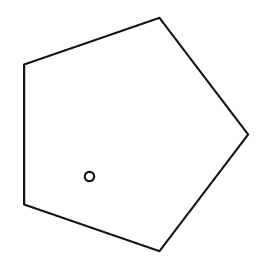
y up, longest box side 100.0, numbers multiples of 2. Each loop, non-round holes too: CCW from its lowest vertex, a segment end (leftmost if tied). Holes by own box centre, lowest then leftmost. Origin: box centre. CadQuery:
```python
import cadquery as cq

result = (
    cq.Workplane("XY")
    .moveTo(10.0, -50.0)
    .lineTo(48.0, 0.0)
    .lineTo(10.0, 50.0)
    .lineTo(-48.0, 30.0)
    .lineTo(-48.0, -30.0)
    .close()
    .moveTo(-20.0, -18.0)
    .circle(2.0)
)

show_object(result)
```